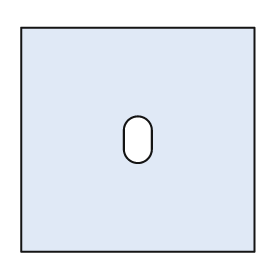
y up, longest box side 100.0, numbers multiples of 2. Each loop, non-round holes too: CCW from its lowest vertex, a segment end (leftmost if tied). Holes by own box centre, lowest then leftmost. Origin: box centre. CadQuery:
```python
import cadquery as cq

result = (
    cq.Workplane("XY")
    .moveTo(-50.0, -48.0)
    .lineTo(50.0, -48.0)
    .lineTo(50.0, 48.0)
    .lineTo(-50.0, 48.0)
    .close()
    .moveTo(-6.0, -4.0)
    .threePointArc((0.0, -10.0), (6.0, -4.0))
    .lineTo(6.0, 4.0)
    .threePointArc((0.0, 10.0), (-6.0, 4.0))
    .close()
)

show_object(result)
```